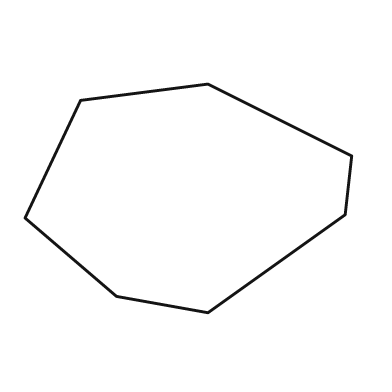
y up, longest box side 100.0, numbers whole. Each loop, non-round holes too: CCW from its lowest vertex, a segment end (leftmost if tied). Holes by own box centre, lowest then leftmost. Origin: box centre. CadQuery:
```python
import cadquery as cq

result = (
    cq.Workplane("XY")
    .moveTo(6.0, -35.0)
    .lineTo(48.0, -5.0)
    .lineTo(50.0, 13.0)
    .lineTo(6.0, 35.0)
    .lineTo(-33.0, 30.0)
    .lineTo(-50.0, -6.0)
    .lineTo(-22.0, -30.0)
    .close()
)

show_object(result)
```